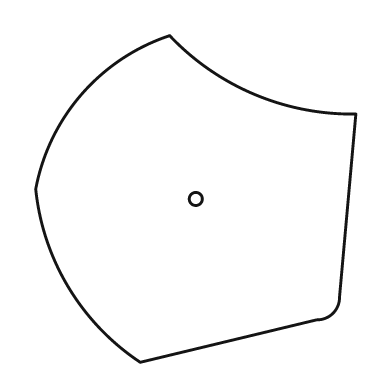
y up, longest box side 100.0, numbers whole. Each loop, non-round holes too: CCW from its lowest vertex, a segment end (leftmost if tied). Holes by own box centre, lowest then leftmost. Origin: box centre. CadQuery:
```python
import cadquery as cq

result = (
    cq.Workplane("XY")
    .moveTo(-17.0, -50.0)
    .lineTo(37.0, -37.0)
    .threePointArc((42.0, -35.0), (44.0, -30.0))
    .lineTo(49.0, 26.0)
    .threePointArc((18.0, 32.0), (-8.0, 50.0))
    .threePointArc((-35.0, 32.0), (-49.0, 3.0))
    .threePointArc((-39.0, -27.0), (-17.0, -50.0))
    .close()
    .moveTo(0.0, 0.0)
    .circle(2.0)
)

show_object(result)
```